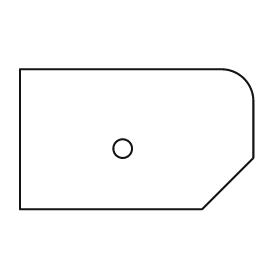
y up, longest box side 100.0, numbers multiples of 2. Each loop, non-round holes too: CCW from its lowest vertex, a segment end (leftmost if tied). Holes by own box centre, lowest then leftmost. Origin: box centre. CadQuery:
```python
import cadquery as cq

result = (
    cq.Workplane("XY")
    .moveTo(-50.0, -30.0)
    .lineTo(28.0, -30.0)
    .lineTo(50.0, -8.0)
    .lineTo(50.0, 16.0)
    .threePointArc((46.0, 26.0), (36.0, 30.0))
    .lineTo(-50.0, 30.0)
    .close()
    .moveTo(-6.0, -4.0)
    .circle(4.0)
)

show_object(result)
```